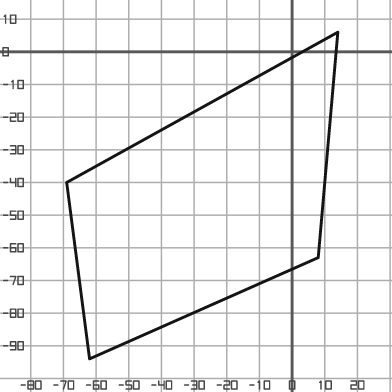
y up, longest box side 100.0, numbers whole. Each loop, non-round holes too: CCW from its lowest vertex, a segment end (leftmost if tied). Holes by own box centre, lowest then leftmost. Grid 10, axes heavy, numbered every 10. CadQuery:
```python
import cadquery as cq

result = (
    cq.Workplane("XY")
    .moveTo(-62.0, -94.0)
    .lineTo(8.0, -63.0)
    .lineTo(14.0, 6.0)
    .lineTo(-69.0, -40.0)
    .close()
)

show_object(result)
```